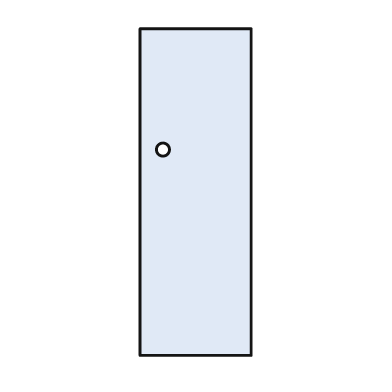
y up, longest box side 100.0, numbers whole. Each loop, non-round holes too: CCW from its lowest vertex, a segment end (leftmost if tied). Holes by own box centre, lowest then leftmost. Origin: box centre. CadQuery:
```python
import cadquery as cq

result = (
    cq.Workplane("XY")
    .moveTo(-17.0, -50.0)
    .lineTo(17.0, -50.0)
    .lineTo(17.0, 50.0)
    .lineTo(-17.0, 50.0)
    .close()
    .moveTo(-10.0, 13.0)
    .circle(2.0)
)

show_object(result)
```